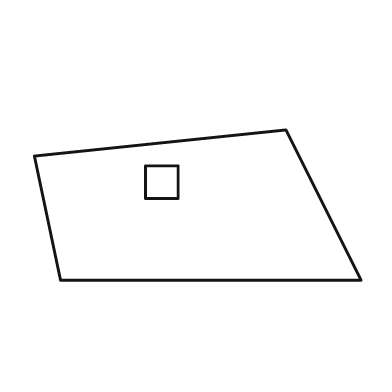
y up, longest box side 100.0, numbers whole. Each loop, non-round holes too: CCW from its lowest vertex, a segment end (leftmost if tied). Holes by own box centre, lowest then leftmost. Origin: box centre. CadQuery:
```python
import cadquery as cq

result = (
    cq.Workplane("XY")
    .moveTo(-42.0, -23.0)
    .lineTo(50.0, -23.0)
    .lineTo(27.0, 23.0)
    .lineTo(-50.0, 15.0)
    .close()
    .moveTo(-16.0, 2.0)
    .lineTo(-6.0, 2.0)
    .lineTo(-6.0, 12.0)
    .lineTo(-16.0, 12.0)
    .close()
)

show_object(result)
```